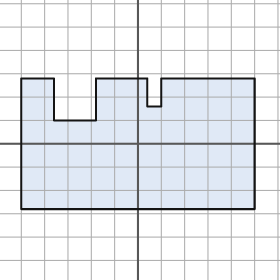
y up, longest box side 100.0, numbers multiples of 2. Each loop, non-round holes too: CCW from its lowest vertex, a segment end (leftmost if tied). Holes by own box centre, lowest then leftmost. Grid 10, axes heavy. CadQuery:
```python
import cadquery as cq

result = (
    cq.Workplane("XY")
    .moveTo(-50.0, -28.0)
    .lineTo(50.0, -28.0)
    .lineTo(50.0, 28.0)
    .lineTo(10.0, 28.0)
    .lineTo(10.0, 16.0)
    .lineTo(4.0, 16.0)
    .lineTo(4.0, 28.0)
    .lineTo(-18.0, 28.0)
    .lineTo(-18.0, 10.0)
    .lineTo(-36.0, 10.0)
    .lineTo(-36.0, 28.0)
    .lineTo(-50.0, 28.0)
    .close()
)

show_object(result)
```